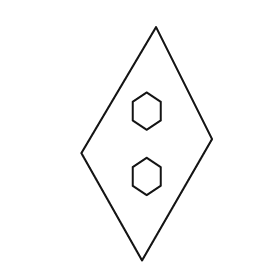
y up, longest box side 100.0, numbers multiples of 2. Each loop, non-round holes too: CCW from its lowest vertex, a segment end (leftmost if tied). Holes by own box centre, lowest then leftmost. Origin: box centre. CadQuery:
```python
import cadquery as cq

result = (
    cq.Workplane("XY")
    .moveTo(-2.0, -50.0)
    .lineTo(28.0, 2.0)
    .lineTo(4.0, 50.0)
    .lineTo(-28.0, -4.0)
    .close()
    .moveTo(0.0, -22.0)
    .lineTo(6.0, -18.0)
    .lineTo(6.0, -10.0)
    .lineTo(0.0, -6.0)
    .lineTo(-6.0, -10.0)
    .lineTo(-6.0, -18.0)
    .close()
    .moveTo(0.0, 6.0)
    .lineTo(6.0, 10.0)
    .lineTo(6.0, 18.0)
    .lineTo(0.0, 22.0)
    .lineTo(-6.0, 18.0)
    .lineTo(-6.0, 10.0)
    .close()
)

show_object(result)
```